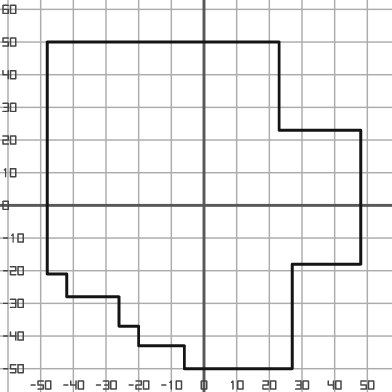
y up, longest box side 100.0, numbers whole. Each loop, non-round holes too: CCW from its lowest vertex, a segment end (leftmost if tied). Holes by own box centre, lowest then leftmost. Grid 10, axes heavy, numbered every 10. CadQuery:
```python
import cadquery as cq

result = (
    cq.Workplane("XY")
    .moveTo(-6.0, -50.0)
    .lineTo(27.0, -50.0)
    .lineTo(27.0, -18.0)
    .lineTo(48.0, -18.0)
    .lineTo(48.0, 23.0)
    .lineTo(23.0, 23.0)
    .lineTo(23.0, 50.0)
    .lineTo(-48.0, 50.0)
    .lineTo(-48.0, -21.0)
    .lineTo(-42.0, -21.0)
    .lineTo(-42.0, -28.0)
    .lineTo(-26.0, -28.0)
    .lineTo(-26.0, -37.0)
    .lineTo(-20.0, -37.0)
    .lineTo(-20.0, -43.0)
    .lineTo(-6.0, -43.0)
    .close()
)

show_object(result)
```